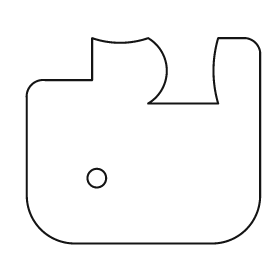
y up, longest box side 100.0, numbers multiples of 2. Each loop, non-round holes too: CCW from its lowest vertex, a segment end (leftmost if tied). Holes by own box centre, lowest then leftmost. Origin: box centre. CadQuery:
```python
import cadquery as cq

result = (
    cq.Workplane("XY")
    .moveTo(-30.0, -44.0)
    .lineTo(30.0, -44.0)
    .threePointArc((44.0, -38.0), (50.0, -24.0))
    .lineTo(50.0, 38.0)
    .threePointArc((48.0, 42.0), (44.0, 44.0))
    .lineTo(32.0, 44.0)
    .threePointArc((30.0, 30.0), (32.0, 16.0))
    .lineTo(2.0, 16.0)
    .threePointArc((10.0, 30.0), (2.0, 44.0))
    .threePointArc((-10.0, 42.0), (-22.0, 44.0))
    .lineTo(-22.0, 26.0)
    .lineTo(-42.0, 26.0)
    .threePointArc((-48.0, 24.0), (-50.0, 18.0))
    .lineTo(-50.0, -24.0)
    .threePointArc((-44.0, -38.0), (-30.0, -44.0))
    .close()
    .moveTo(-20.0, -16.0)
    .circle(4.0)
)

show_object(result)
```